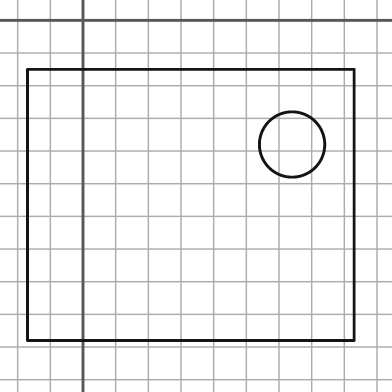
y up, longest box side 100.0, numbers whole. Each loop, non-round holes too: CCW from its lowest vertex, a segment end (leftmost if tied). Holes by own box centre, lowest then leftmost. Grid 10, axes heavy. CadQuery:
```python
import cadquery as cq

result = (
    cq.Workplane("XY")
    .moveTo(-17.0, -98.0)
    .lineTo(83.0, -98.0)
    .lineTo(83.0, -15.0)
    .lineTo(-17.0, -15.0)
    .close()
    .moveTo(64.0, -38.0)
    .circle(10.0)
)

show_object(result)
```